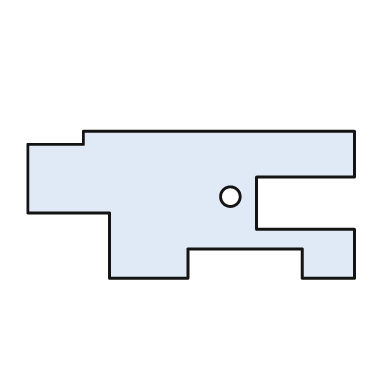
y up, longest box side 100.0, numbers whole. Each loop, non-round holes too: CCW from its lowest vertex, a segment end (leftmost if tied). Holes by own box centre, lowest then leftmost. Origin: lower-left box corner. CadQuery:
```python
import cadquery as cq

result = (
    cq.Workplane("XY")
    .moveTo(25.0, 0.0)
    .lineTo(49.0, 0.0)
    .lineTo(49.0, 9.0)
    .lineTo(84.0, 9.0)
    .lineTo(84.0, 0.0)
    .lineTo(100.0, 0.0)
    .lineTo(100.0, 15.0)
    .lineTo(70.0, 15.0)
    .lineTo(70.0, 31.0)
    .lineTo(100.0, 31.0)
    .lineTo(100.0, 45.0)
    .lineTo(17.0, 45.0)
    .lineTo(17.0, 41.0)
    .lineTo(0.0, 41.0)
    .lineTo(0.0, 20.0)
    .lineTo(25.0, 20.0)
    .close()
    .moveTo(62.0, 25.0)
    .circle(3.0)
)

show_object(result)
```